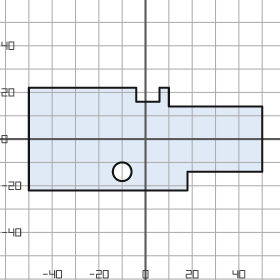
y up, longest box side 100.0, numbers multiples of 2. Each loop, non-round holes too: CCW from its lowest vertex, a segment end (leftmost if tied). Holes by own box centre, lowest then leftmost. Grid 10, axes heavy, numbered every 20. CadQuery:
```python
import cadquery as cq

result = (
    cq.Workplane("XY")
    .moveTo(-50.0, -22.0)
    .lineTo(18.0, -22.0)
    .lineTo(18.0, -14.0)
    .lineTo(50.0, -14.0)
    .lineTo(50.0, 14.0)
    .lineTo(10.0, 14.0)
    .lineTo(10.0, 22.0)
    .lineTo(6.0, 22.0)
    .lineTo(6.0, 16.0)
    .lineTo(-4.0, 16.0)
    .lineTo(-4.0, 22.0)
    .lineTo(-50.0, 22.0)
    .close()
    .moveTo(-10.0, -14.0)
    .circle(4.0)
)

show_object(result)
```